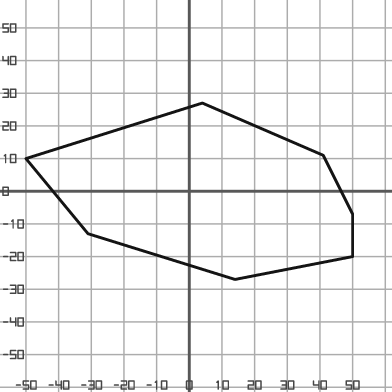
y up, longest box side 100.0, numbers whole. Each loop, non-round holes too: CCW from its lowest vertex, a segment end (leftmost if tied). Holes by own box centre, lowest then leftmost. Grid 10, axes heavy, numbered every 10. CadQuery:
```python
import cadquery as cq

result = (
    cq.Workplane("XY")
    .moveTo(14.0, -27.0)
    .lineTo(50.0, -20.0)
    .lineTo(50.0, -7.0)
    .lineTo(41.0, 11.0)
    .lineTo(4.0, 27.0)
    .lineTo(-50.0, 10.0)
    .lineTo(-31.0, -13.0)
    .close()
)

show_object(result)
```